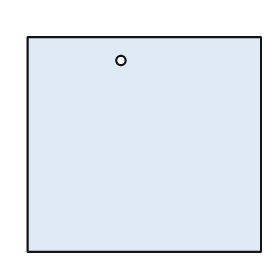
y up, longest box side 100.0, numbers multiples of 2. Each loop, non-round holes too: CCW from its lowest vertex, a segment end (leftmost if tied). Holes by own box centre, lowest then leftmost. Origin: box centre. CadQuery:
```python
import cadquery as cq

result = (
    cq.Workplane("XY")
    .moveTo(-50.0, -46.0)
    .lineTo(50.0, -46.0)
    .lineTo(50.0, 46.0)
    .lineTo(-50.0, 46.0)
    .close()
    .moveTo(-10.0, 36.0)
    .circle(2.0)
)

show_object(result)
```